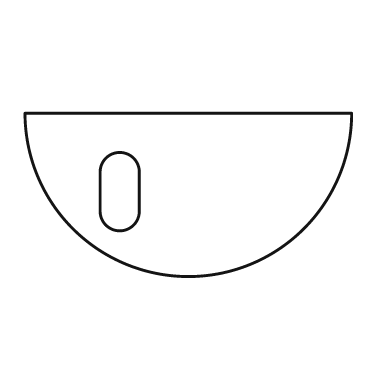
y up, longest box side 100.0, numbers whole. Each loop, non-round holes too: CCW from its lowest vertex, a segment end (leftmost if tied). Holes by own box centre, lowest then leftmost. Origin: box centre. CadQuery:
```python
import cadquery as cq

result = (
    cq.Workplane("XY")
    .moveTo(-50.0, 25.0)
    .threePointArc((0.0, -25.0), (50.0, 25.0))
    .close()
    .moveTo(-27.0, -5.0)
    .threePointArc((-21.0, -11.0), (-15.0, -5.0))
    .lineTo(-15.0, 7.0)
    .threePointArc((-21.0, 13.0), (-27.0, 7.0))
    .close()
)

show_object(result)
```